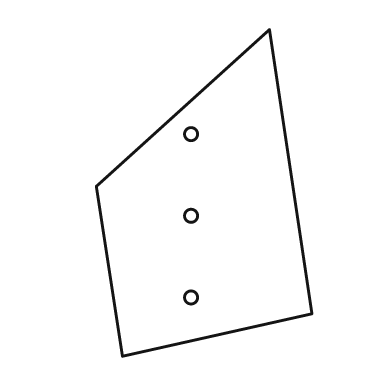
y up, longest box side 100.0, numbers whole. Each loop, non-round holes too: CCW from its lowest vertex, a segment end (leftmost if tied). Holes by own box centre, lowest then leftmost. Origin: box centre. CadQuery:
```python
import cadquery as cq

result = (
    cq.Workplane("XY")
    .moveTo(-25.0, -50.0)
    .lineTo(33.0, -37.0)
    .lineTo(20.0, 50.0)
    .lineTo(-33.0, 2.0)
    .close()
    .moveTo(-4.0, -32.0)
    .circle(2.0)
    .moveTo(-4.0, -7.0)
    .circle(2.0)
    .moveTo(-4.0, 18.0)
    .circle(2.0)
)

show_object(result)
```